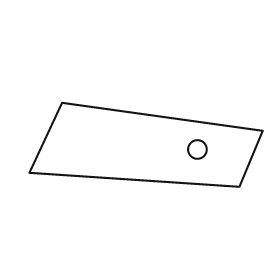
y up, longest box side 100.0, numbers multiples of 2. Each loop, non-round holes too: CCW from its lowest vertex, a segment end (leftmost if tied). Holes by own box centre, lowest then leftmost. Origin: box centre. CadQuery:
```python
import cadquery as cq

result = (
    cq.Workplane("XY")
    .moveTo(40.0, -18.0)
    .lineTo(50.0, 6.0)
    .lineTo(-36.0, 18.0)
    .lineTo(-50.0, -12.0)
    .close()
    .moveTo(22.0, -2.0)
    .circle(4.0)
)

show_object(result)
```